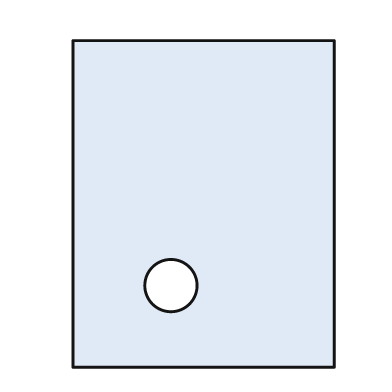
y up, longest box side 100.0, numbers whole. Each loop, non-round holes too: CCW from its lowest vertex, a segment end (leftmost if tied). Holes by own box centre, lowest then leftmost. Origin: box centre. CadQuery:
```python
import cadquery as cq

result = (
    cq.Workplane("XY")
    .moveTo(-40.0, -50.0)
    .lineTo(40.0, -50.0)
    .lineTo(40.0, 50.0)
    .lineTo(-40.0, 50.0)
    .close()
    .moveTo(-10.0, -25.0)
    .circle(8.0)
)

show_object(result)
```